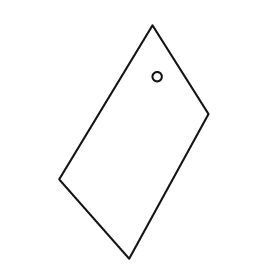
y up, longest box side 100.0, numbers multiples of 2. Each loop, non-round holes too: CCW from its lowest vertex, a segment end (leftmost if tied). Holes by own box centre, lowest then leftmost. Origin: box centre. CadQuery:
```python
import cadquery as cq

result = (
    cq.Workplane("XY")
    .moveTo(-2.0, -50.0)
    .lineTo(32.0, 12.0)
    .lineTo(8.0, 50.0)
    .lineTo(-32.0, -16.0)
    .close()
    .moveTo(10.0, 28.0)
    .circle(2.0)
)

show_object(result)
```